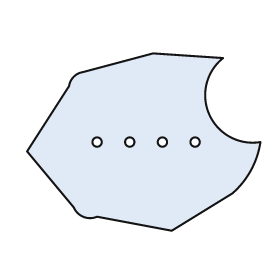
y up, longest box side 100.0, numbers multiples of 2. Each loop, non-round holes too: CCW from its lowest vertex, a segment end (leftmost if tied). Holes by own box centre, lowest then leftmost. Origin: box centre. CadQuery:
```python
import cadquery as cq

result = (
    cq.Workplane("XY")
    .moveTo(12.0, -38.0)
    .lineTo(38.0, -22.0)
    .threePointArc((46.0, -12.0), (50.0, 0.0))
    .threePointArc((28.0, 12.0), (34.0, 36.0))
    .lineTo(4.0, 38.0)
    .lineTo(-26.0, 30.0)
    .threePointArc((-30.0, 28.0), (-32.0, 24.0))
    .lineTo(-50.0, -4.0)
    .lineTo(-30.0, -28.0)
    .threePointArc((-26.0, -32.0), (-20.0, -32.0))
    .close()
    .moveTo(-20.0, 0.0)
    .circle(2.0)
    .moveTo(-6.0, 0.0)
    .circle(2.0)
    .moveTo(8.0, 0.0)
    .circle(2.0)
    .moveTo(22.0, 0.0)
    .circle(2.0)
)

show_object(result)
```